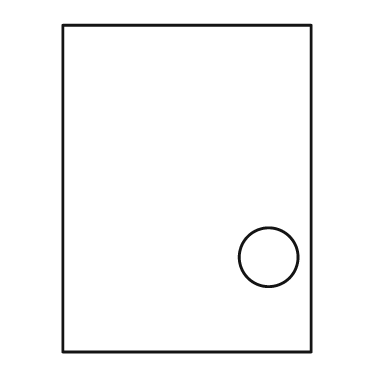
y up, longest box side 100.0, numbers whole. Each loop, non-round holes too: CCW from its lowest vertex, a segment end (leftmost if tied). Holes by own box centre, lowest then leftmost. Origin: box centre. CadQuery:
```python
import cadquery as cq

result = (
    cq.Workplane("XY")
    .moveTo(-38.0, -50.0)
    .lineTo(38.0, -50.0)
    .lineTo(38.0, 50.0)
    .lineTo(-38.0, 50.0)
    .close()
    .moveTo(25.0, -21.0)
    .circle(9.0)
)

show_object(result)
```